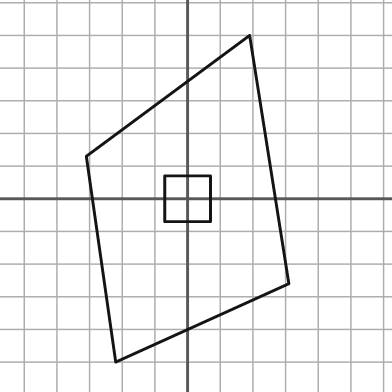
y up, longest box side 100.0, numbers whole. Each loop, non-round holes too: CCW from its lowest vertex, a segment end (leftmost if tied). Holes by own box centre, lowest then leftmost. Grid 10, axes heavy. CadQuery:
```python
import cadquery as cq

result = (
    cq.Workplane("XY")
    .moveTo(-22.0, -50.0)
    .lineTo(31.0, -26.0)
    .lineTo(19.0, 50.0)
    .lineTo(-31.0, 13.0)
    .close()
    .moveTo(-7.0, -7.0)
    .lineTo(7.0, -7.0)
    .lineTo(7.0, 7.0)
    .lineTo(-7.0, 7.0)
    .close()
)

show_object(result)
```